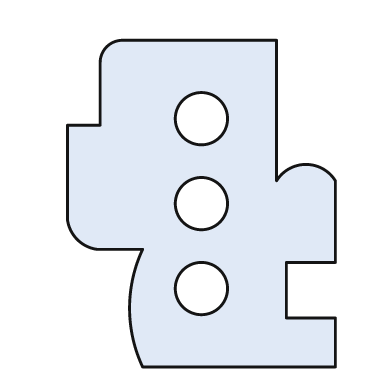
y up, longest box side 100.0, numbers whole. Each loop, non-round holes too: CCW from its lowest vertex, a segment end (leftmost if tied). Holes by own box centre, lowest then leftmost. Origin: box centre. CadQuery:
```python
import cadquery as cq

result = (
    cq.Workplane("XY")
    .moveTo(-18.0, -50.0)
    .lineTo(41.0, -50.0)
    .lineTo(41.0, -35.0)
    .lineTo(26.0, -35.0)
    .lineTo(26.0, -18.0)
    .lineTo(41.0, -18.0)
    .lineTo(41.0, 7.0)
    .threePointArc((32.0, 12.0), (23.0, 7.0))
    .lineTo(23.0, 50.0)
    .lineTo(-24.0, 50.0)
    .threePointArc((-29.0, 48.0), (-31.0, 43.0))
    .lineTo(-31.0, 24.0)
    .lineTo(-41.0, 24.0)
    .lineTo(-41.0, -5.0)
    .threePointArc((-38.0, -11.0), (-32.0, -14.0))
    .lineTo(-18.0, -14.0)
    .threePointArc((-22.0, -32.0), (-18.0, -50.0))
    .close()
    .moveTo(0.0, -26.0)
    .circle(8.0)
    .moveTo(0.0, 0.0)
    .circle(8.0)
    .moveTo(0.0, 26.0)
    .circle(8.0)
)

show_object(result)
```